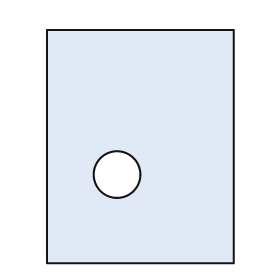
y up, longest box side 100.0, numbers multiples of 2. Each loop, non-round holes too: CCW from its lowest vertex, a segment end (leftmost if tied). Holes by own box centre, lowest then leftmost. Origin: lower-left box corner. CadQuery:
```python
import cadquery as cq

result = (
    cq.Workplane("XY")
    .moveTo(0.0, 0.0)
    .lineTo(80.0, 0.0)
    .lineTo(80.0, 100.0)
    .lineTo(0.0, 100.0)
    .close()
    .moveTo(30.0, 38.0)
    .circle(10.0)
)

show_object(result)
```